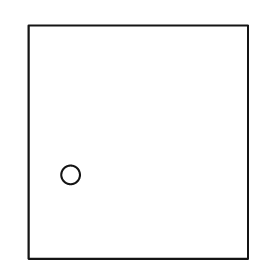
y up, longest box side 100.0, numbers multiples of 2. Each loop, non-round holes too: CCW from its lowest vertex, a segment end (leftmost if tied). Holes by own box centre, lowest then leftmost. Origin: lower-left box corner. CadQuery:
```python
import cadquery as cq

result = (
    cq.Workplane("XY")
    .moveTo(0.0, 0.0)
    .lineTo(94.0, 0.0)
    .lineTo(94.0, 100.0)
    .lineTo(0.0, 100.0)
    .close()
    .moveTo(18.0, 36.0)
    .circle(4.0)
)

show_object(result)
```